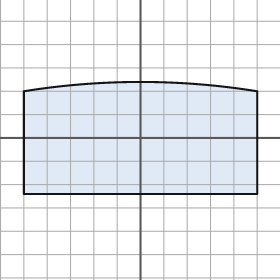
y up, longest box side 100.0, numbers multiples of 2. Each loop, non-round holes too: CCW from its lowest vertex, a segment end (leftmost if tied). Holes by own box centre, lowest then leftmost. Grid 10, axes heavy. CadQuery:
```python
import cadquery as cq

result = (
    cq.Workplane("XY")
    .moveTo(-50.0, -24.0)
    .lineTo(50.0, -24.0)
    .lineTo(50.0, 20.0)
    .threePointArc((0.0, 24.0), (-50.0, 20.0))
    .close()
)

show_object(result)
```